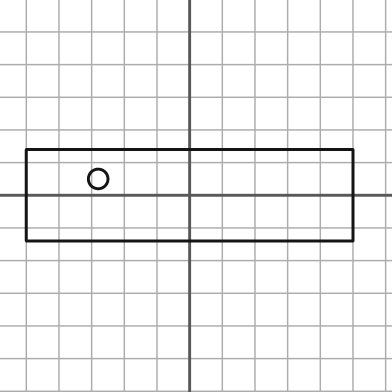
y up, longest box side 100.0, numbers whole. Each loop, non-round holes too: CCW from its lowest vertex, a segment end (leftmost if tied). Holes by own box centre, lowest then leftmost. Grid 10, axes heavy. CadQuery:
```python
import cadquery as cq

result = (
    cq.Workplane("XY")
    .moveTo(-50.0, -14.0)
    .lineTo(50.0, -14.0)
    .lineTo(50.0, 14.0)
    .lineTo(-50.0, 14.0)
    .close()
    .moveTo(-28.0, 5.0)
    .circle(3.0)
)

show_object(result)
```